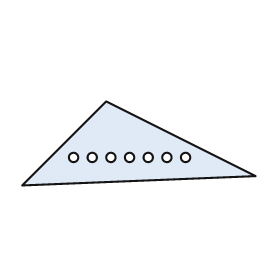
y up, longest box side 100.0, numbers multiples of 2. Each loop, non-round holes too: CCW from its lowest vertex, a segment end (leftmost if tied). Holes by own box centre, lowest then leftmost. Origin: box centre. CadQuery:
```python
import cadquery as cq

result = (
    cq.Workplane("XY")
    .moveTo(-50.0, -18.0)
    .lineTo(50.0, -14.0)
    .lineTo(-14.0, 18.0)
    .close()
    .moveTo(-28.0, -6.0)
    .circle(2.0)
    .moveTo(-20.0, -6.0)
    .circle(2.0)
    .moveTo(-12.0, -6.0)
    .circle(2.0)
    .moveTo(-4.0, -6.0)
    .circle(2.0)
    .moveTo(4.0, -6.0)
    .circle(2.0)
    .moveTo(12.0, -6.0)
    .circle(2.0)
    .moveTo(20.0, -6.0)
    .circle(2.0)
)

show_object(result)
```